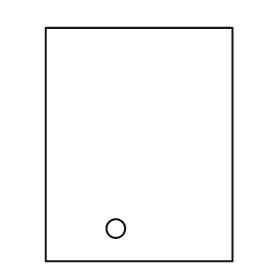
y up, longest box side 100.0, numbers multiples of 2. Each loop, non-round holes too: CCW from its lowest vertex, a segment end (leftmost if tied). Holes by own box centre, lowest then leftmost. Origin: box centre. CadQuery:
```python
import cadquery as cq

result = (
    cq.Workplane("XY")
    .moveTo(-40.0, -50.0)
    .lineTo(40.0, -50.0)
    .lineTo(40.0, 50.0)
    .lineTo(-40.0, 50.0)
    .close()
    .moveTo(-10.0, -36.0)
    .circle(4.0)
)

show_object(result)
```